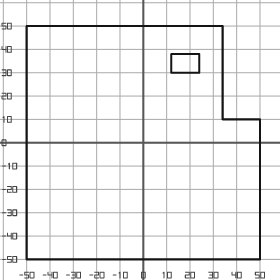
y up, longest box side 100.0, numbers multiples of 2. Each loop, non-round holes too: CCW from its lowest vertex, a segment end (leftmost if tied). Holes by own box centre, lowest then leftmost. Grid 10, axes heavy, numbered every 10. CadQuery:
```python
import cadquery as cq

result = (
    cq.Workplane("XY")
    .moveTo(-50.0, -50.0)
    .lineTo(50.0, -50.0)
    .lineTo(50.0, 10.0)
    .lineTo(34.0, 10.0)
    .lineTo(34.0, 50.0)
    .lineTo(-50.0, 50.0)
    .close()
    .moveTo(12.0, 30.0)
    .lineTo(24.0, 30.0)
    .lineTo(24.0, 38.0)
    .lineTo(12.0, 38.0)
    .close()
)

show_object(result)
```